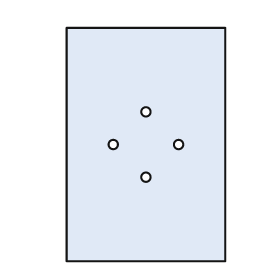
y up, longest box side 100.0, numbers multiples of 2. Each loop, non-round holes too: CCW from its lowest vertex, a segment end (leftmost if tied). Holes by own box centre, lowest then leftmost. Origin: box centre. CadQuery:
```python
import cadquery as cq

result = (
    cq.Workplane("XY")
    .moveTo(-34.0, -50.0)
    .lineTo(34.0, -50.0)
    .lineTo(34.0, 50.0)
    .lineTo(-34.0, 50.0)
    .close()
    .moveTo(0.0, -14.0)
    .circle(2.0)
    .moveTo(-14.0, 0.0)
    .circle(2.0)
    .moveTo(14.0, 0.0)
    .circle(2.0)
    .moveTo(0.0, 14.0)
    .circle(2.0)
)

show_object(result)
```